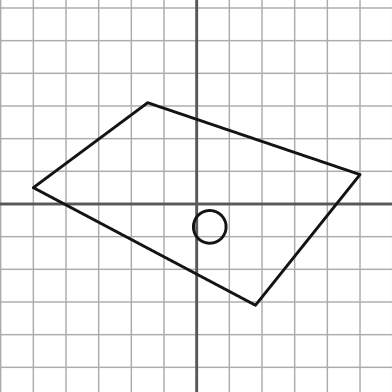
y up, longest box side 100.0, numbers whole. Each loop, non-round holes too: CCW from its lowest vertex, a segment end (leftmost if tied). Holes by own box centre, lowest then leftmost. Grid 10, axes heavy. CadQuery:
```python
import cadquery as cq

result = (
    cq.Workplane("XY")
    .moveTo(18.0, -31.0)
    .lineTo(50.0, 9.0)
    .lineTo(-15.0, 31.0)
    .lineTo(-50.0, 5.0)
    .close()
    .moveTo(4.0, -7.0)
    .circle(5.0)
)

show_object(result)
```